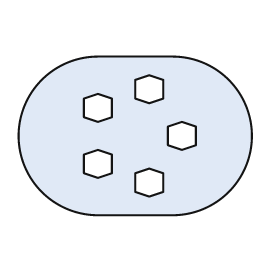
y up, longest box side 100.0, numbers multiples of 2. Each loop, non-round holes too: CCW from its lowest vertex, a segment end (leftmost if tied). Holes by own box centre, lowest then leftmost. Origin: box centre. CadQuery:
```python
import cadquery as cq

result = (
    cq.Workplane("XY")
    .moveTo(-16.0, -34.0)
    .lineTo(16.0, -34.0)
    .threePointArc((50.0, 0.0), (16.0, 34.0))
    .lineTo(-16.0, 34.0)
    .threePointArc((-50.0, 0.0), (-16.0, -34.0))
    .close()
    .moveTo(6.0, -26.0)
    .lineTo(12.0, -24.0)
    .lineTo(12.0, -16.0)
    .lineTo(6.0, -14.0)
    .lineTo(0.0, -16.0)
    .lineTo(0.0, -24.0)
    .close()
    .moveTo(-16.0, -18.0)
    .lineTo(-10.0, -16.0)
    .lineTo(-10.0, -8.0)
    .lineTo(-16.0, -6.0)
    .lineTo(-22.0, -8.0)
    .lineTo(-22.0, -16.0)
    .close()
    .moveTo(20.0, -6.0)
    .lineTo(26.0, -4.0)
    .lineTo(26.0, 4.0)
    .lineTo(20.0, 6.0)
    .lineTo(14.0, 4.0)
    .lineTo(14.0, -4.0)
    .close()
    .moveTo(-16.0, 6.0)
    .lineTo(-10.0, 8.0)
    .lineTo(-10.0, 16.0)
    .lineTo(-16.0, 18.0)
    .lineTo(-22.0, 16.0)
    .lineTo(-22.0, 8.0)
    .close()
    .moveTo(6.0, 14.0)
    .lineTo(12.0, 16.0)
    .lineTo(12.0, 24.0)
    .lineTo(6.0, 26.0)
    .lineTo(0.0, 24.0)
    .lineTo(0.0, 16.0)
    .close()
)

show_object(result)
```